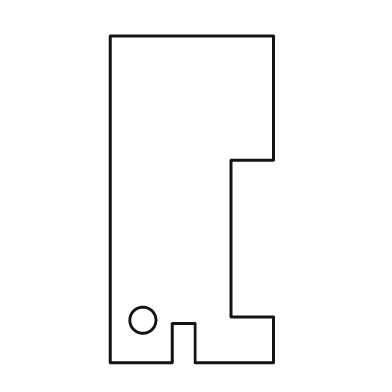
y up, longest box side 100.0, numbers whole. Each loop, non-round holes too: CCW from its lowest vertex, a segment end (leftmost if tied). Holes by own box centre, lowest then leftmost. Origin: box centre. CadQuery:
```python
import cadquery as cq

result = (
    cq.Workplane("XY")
    .moveTo(-25.0, -50.0)
    .lineTo(-6.0, -50.0)
    .lineTo(-6.0, -38.0)
    .lineTo(1.0, -38.0)
    .lineTo(1.0, -50.0)
    .lineTo(25.0, -50.0)
    .lineTo(25.0, -36.0)
    .lineTo(12.0, -36.0)
    .lineTo(12.0, 12.0)
    .lineTo(25.0, 12.0)
    .lineTo(25.0, 50.0)
    .lineTo(-25.0, 50.0)
    .close()
    .moveTo(-15.0, -37.0)
    .circle(4.0)
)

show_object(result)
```